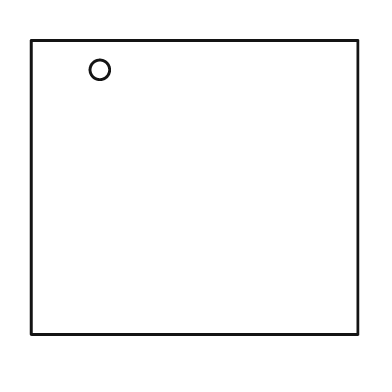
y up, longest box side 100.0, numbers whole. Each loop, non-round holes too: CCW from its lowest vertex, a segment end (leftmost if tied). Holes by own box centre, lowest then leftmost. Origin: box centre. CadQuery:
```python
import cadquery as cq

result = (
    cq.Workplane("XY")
    .moveTo(-50.0, -45.0)
    .lineTo(50.0, -45.0)
    .lineTo(50.0, 45.0)
    .lineTo(-50.0, 45.0)
    .close()
    .moveTo(-29.0, 36.0)
    .circle(3.0)
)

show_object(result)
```